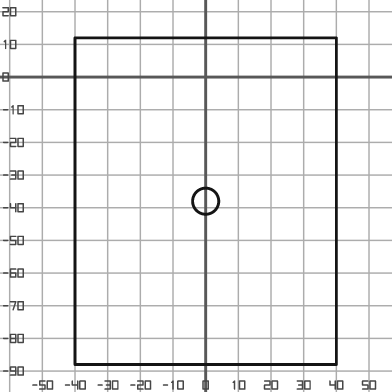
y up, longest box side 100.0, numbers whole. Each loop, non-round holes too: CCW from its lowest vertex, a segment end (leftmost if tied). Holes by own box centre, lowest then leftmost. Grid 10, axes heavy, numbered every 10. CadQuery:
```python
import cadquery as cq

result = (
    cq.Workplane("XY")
    .moveTo(-40.0, -88.0)
    .lineTo(40.0, -88.0)
    .lineTo(40.0, 12.0)
    .lineTo(-40.0, 12.0)
    .close()
    .moveTo(0.0, -38.0)
    .circle(4.0)
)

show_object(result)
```